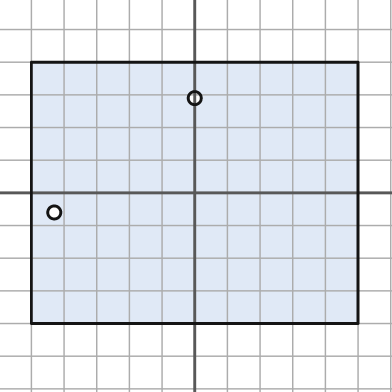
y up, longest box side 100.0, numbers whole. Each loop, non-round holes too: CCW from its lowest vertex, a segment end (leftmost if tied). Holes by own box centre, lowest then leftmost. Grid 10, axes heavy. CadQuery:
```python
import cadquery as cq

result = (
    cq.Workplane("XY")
    .moveTo(-50.0, -40.0)
    .lineTo(50.0, -40.0)
    .lineTo(50.0, 40.0)
    .lineTo(-50.0, 40.0)
    .close()
    .moveTo(-43.0, -6.0)
    .circle(2.0)
    .moveTo(0.0, 29.0)
    .circle(2.0)
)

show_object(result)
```